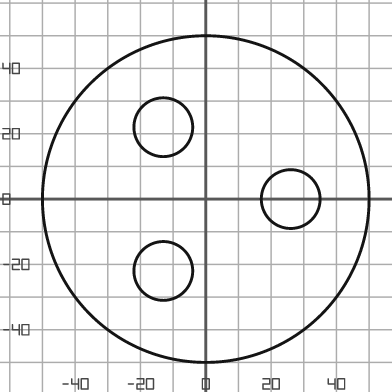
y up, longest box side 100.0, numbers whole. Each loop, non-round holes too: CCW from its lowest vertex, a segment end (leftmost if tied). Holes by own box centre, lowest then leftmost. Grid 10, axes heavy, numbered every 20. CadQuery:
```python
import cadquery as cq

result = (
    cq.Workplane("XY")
    .moveTo(0.0, 0.0)
    .circle(50.0)
    .moveTo(-13.0, -22.0)
    .circle(9.0)
    .moveTo(26.0, 0.0)
    .circle(9.0)
    .moveTo(-13.0, 22.0)
    .circle(9.0)
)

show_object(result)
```